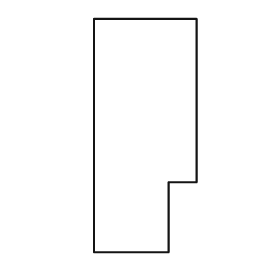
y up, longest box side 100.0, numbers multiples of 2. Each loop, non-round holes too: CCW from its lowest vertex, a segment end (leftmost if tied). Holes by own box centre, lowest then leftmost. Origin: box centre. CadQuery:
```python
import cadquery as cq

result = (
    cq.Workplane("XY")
    .moveTo(-22.0, -50.0)
    .lineTo(10.0, -50.0)
    .lineTo(10.0, -20.0)
    .lineTo(22.0, -20.0)
    .lineTo(22.0, 50.0)
    .lineTo(-22.0, 50.0)
    .close()
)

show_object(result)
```